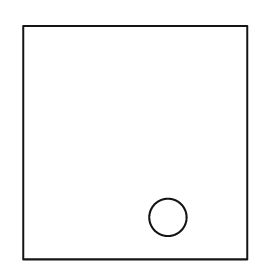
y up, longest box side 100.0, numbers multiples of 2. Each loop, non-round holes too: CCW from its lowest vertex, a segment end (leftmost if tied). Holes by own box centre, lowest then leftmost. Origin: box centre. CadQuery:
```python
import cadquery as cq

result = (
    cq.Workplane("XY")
    .moveTo(-48.0, -50.0)
    .lineTo(48.0, -50.0)
    .lineTo(48.0, 50.0)
    .lineTo(-48.0, 50.0)
    .close()
    .moveTo(14.0, -32.0)
    .circle(8.0)
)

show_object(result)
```